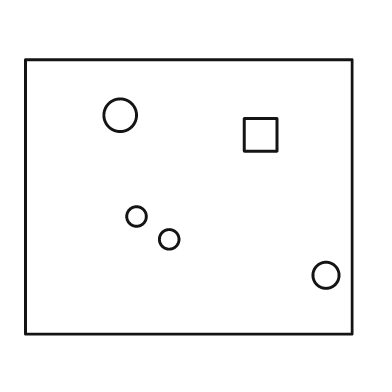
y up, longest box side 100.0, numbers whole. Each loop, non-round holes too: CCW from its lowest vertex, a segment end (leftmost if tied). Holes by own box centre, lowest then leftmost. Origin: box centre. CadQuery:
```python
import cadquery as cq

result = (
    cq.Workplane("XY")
    .moveTo(-50.0, -42.0)
    .lineTo(50.0, -42.0)
    .lineTo(50.0, 42.0)
    .lineTo(-50.0, 42.0)
    .close()
    .moveTo(42.0, -24.0)
    .circle(4.0)
    .moveTo(-6.0, -13.0)
    .circle(3.0)
    .moveTo(-16.0, -6.0)
    .circle(3.0)
    .moveTo(17.0, 14.0)
    .lineTo(27.0, 14.0)
    .lineTo(27.0, 24.0)
    .lineTo(17.0, 24.0)
    .close()
    .moveTo(-21.0, 25.0)
    .circle(5.0)
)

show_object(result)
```